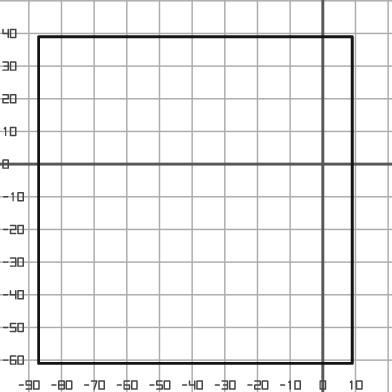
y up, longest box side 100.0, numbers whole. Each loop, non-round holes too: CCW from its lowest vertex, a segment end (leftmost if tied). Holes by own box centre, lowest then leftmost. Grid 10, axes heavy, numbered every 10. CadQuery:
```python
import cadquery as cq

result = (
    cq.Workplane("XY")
    .moveTo(-87.0, -61.0)
    .lineTo(9.0, -61.0)
    .lineTo(9.0, 39.0)
    .lineTo(-87.0, 39.0)
    .close()
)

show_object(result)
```